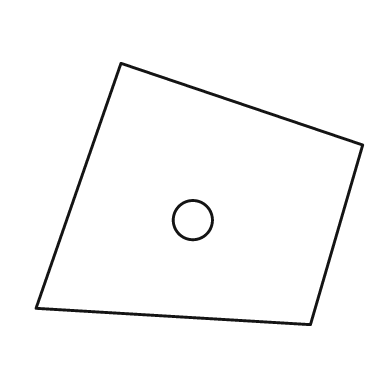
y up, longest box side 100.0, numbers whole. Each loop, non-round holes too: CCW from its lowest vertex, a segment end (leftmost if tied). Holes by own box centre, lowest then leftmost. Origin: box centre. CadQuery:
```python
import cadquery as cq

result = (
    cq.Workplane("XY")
    .moveTo(34.0, -40.0)
    .lineTo(50.0, 15.0)
    .lineTo(-24.0, 40.0)
    .lineTo(-50.0, -35.0)
    .close()
    .moveTo(-2.0, -8.0)
    .circle(6.0)
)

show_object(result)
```